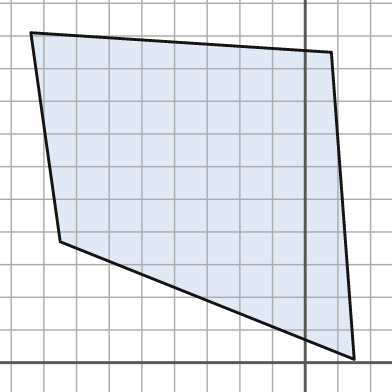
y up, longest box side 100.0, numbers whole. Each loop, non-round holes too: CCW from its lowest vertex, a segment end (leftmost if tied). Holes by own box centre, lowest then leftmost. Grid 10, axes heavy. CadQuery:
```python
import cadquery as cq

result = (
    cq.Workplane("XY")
    .moveTo(15.0, 1.0)
    .lineTo(8.0, 95.0)
    .lineTo(-84.0, 101.0)
    .lineTo(-75.0, 37.0)
    .close()
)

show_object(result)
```